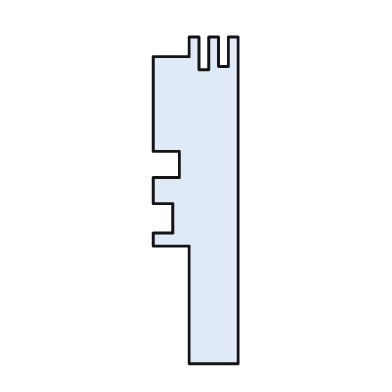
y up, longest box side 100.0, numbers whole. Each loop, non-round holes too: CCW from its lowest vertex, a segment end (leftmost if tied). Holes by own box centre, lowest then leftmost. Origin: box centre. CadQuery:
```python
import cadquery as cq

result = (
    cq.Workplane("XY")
    .moveTo(-2.0, -50.0)
    .lineTo(13.0, -50.0)
    .lineTo(13.0, 50.0)
    .lineTo(10.0, 50.0)
    .lineTo(10.0, 41.0)
    .lineTo(7.0, 41.0)
    .lineTo(7.0, 50.0)
    .lineTo(4.0, 50.0)
    .lineTo(4.0, 40.0)
    .lineTo(1.0, 40.0)
    .lineTo(1.0, 50.0)
    .lineTo(-2.0, 50.0)
    .lineTo(-2.0, 44.0)
    .lineTo(-13.0, 44.0)
    .lineTo(-13.0, 15.0)
    .lineTo(-5.0, 15.0)
    .lineTo(-5.0, 7.0)
    .lineTo(-13.0, 7.0)
    .lineTo(-13.0, -1.0)
    .lineTo(-7.0, -1.0)
    .lineTo(-7.0, -10.0)
    .lineTo(-13.0, -10.0)
    .lineTo(-13.0, -14.0)
    .lineTo(-2.0, -14.0)
    .close()
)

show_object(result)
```